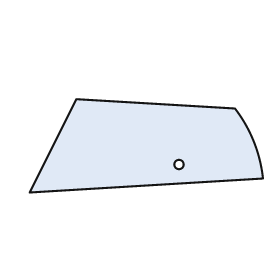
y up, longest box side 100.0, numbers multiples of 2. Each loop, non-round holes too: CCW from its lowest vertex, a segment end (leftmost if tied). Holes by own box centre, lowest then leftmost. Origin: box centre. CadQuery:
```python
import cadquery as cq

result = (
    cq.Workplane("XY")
    .moveTo(-50.0, -20.0)
    .lineTo(50.0, -14.0)
    .threePointArc((46.0, 2.0), (38.0, 16.0))
    .lineTo(-30.0, 20.0)
    .close()
    .moveTo(14.0, -8.0)
    .circle(2.0)
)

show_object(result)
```